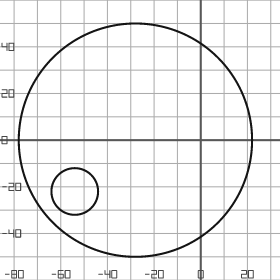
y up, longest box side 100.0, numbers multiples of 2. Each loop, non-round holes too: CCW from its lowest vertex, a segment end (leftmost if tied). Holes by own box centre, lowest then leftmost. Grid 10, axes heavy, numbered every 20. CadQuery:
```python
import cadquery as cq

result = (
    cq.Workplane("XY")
    .moveTo(-28.0, 0.0)
    .circle(50.0)
    .moveTo(-54.0, -22.0)
    .circle(10.0)
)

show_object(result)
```